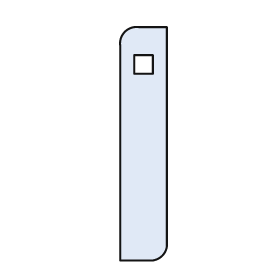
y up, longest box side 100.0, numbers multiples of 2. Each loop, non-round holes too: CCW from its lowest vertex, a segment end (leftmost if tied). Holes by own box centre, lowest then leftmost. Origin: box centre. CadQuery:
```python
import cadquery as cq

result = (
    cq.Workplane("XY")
    .moveTo(-10.0, -50.0)
    .lineTo(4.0, -50.0)
    .threePointArc((8.0, -48.0), (10.0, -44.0))
    .lineTo(10.0, 50.0)
    .lineTo(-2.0, 50.0)
    .threePointArc((-8.0, 48.0), (-10.0, 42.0))
    .close()
    .moveTo(-4.0, 30.0)
    .lineTo(4.0, 30.0)
    .lineTo(4.0, 38.0)
    .lineTo(-4.0, 38.0)
    .close()
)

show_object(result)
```